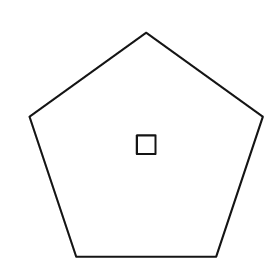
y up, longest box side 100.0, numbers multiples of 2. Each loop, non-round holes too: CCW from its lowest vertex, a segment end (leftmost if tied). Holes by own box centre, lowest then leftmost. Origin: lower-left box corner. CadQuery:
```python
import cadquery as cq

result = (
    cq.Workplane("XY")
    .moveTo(20.0, 0.0)
    .lineTo(80.0, 0.0)
    .lineTo(100.0, 60.0)
    .lineTo(50.0, 96.0)
    .lineTo(0.0, 60.0)
    .close()
    .moveTo(46.0, 44.0)
    .lineTo(54.0, 44.0)
    .lineTo(54.0, 52.0)
    .lineTo(46.0, 52.0)
    .close()
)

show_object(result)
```